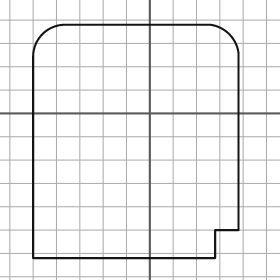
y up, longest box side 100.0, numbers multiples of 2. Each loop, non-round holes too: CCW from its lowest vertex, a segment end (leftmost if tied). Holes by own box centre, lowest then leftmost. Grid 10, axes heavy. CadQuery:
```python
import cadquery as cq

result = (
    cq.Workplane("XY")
    .moveTo(-50.0, -62.0)
    .lineTo(28.0, -62.0)
    .lineTo(28.0, -50.0)
    .lineTo(38.0, -50.0)
    .lineTo(38.0, 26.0)
    .threePointArc((34.0, 34.0), (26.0, 38.0))
    .lineTo(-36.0, 38.0)
    .threePointArc((-46.0, 34.0), (-50.0, 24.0))
    .close()
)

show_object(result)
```